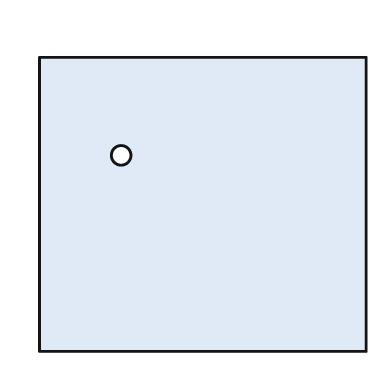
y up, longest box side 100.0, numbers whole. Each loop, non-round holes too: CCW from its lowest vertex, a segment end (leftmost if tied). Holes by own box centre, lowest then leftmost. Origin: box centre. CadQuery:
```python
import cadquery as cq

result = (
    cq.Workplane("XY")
    .moveTo(-50.0, -45.0)
    .lineTo(50.0, -45.0)
    .lineTo(50.0, 45.0)
    .lineTo(-50.0, 45.0)
    .close()
    .moveTo(-25.0, 15.0)
    .circle(3.0)
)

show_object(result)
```